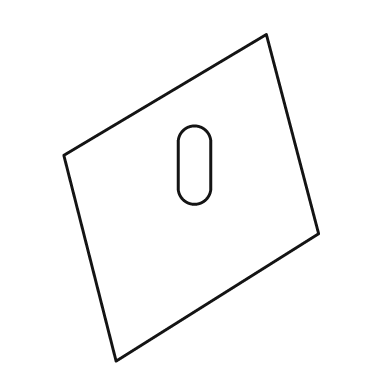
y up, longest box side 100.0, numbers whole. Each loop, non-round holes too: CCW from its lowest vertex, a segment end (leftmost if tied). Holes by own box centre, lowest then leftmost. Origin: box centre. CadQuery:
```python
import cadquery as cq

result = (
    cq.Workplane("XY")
    .moveTo(-23.0, -50.0)
    .lineTo(39.0, -11.0)
    .lineTo(23.0, 50.0)
    .lineTo(-39.0, 13.0)
    .close()
    .moveTo(-4.0, 3.0)
    .threePointArc((1.0, -2.0), (6.0, 3.0))
    .lineTo(6.0, 17.0)
    .threePointArc((1.0, 22.0), (-4.0, 17.0))
    .close()
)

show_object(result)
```